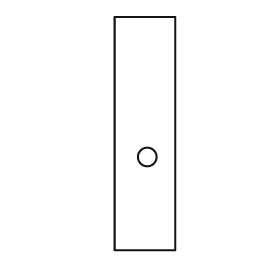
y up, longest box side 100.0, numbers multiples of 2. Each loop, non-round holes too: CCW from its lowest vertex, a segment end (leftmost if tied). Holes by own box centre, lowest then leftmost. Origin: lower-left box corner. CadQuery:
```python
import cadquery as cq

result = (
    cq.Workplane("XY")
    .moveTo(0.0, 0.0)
    .lineTo(26.0, 0.0)
    .lineTo(26.0, 100.0)
    .lineTo(0.0, 100.0)
    .close()
    .moveTo(14.0, 40.0)
    .circle(4.0)
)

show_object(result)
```